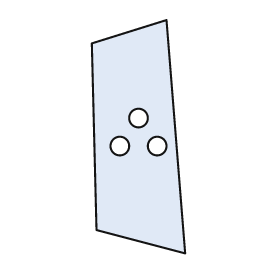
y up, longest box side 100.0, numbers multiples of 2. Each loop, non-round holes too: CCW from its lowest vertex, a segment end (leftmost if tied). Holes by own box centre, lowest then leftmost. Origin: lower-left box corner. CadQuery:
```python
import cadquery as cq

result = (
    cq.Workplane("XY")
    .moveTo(40.0, 0.0)
    .lineTo(32.0, 100.0)
    .lineTo(0.0, 90.0)
    .lineTo(2.0, 10.0)
    .close()
    .moveTo(12.0, 46.0)
    .circle(4.0)
    .moveTo(28.0, 46.0)
    .circle(4.0)
    .moveTo(20.0, 58.0)
    .circle(4.0)
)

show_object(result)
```